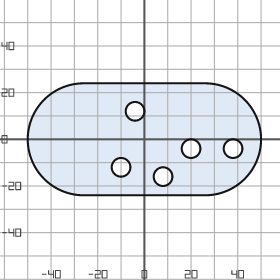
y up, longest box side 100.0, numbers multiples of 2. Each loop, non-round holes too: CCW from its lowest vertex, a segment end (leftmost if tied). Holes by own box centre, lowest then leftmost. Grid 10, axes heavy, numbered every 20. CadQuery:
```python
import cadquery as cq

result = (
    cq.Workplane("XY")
    .moveTo(-26.0, -24.0)
    .lineTo(26.0, -24.0)
    .threePointArc((50.0, 0.0), (26.0, 24.0))
    .lineTo(-26.0, 24.0)
    .threePointArc((-50.0, 0.0), (-26.0, -24.0))
    .close()
    .moveTo(8.0, -16.0)
    .circle(4.0)
    .moveTo(-10.0, -12.0)
    .circle(4.0)
    .moveTo(20.0, -4.0)
    .circle(4.0)
    .moveTo(38.0, -4.0)
    .circle(4.0)
    .moveTo(-4.0, 12.0)
    .circle(4.0)
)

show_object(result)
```